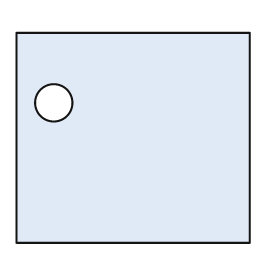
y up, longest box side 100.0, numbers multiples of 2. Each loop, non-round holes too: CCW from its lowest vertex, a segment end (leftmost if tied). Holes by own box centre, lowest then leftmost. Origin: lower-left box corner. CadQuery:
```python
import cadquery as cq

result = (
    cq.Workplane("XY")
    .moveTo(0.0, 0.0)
    .lineTo(100.0, 0.0)
    .lineTo(100.0, 90.0)
    .lineTo(0.0, 90.0)
    .close()
    .moveTo(16.0, 60.0)
    .circle(8.0)
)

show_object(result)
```